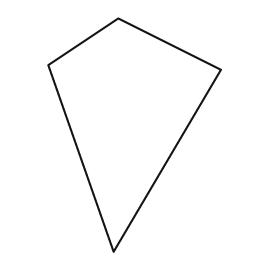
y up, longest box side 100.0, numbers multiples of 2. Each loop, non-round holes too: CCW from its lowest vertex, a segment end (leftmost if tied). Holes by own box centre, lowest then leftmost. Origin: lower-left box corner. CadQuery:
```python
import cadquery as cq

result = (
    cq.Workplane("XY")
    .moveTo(28.0, 0.0)
    .lineTo(74.0, 78.0)
    .lineTo(30.0, 100.0)
    .lineTo(0.0, 80.0)
    .close()
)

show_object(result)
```